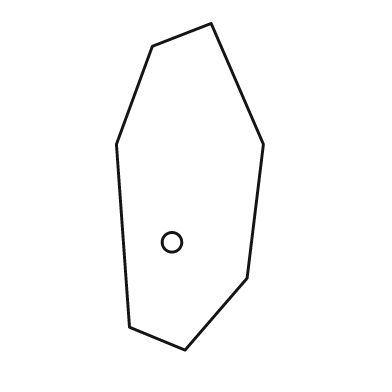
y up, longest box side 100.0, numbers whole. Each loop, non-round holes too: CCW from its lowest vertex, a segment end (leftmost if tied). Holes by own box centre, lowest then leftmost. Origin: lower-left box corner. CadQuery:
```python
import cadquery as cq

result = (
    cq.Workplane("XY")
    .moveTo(21.0, 0.0)
    .lineTo(40.0, 22.0)
    .lineTo(45.0, 63.0)
    .lineTo(29.0, 100.0)
    .lineTo(11.0, 93.0)
    .lineTo(0.0, 63.0)
    .lineTo(4.0, 7.0)
    .close()
    .moveTo(17.0, 33.0)
    .circle(3.0)
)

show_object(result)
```